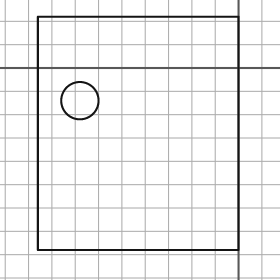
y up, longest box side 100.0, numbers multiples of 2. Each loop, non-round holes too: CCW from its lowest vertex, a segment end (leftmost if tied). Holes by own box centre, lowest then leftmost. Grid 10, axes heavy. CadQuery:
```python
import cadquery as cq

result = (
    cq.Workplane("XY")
    .moveTo(-86.0, -78.0)
    .lineTo(0.0, -78.0)
    .lineTo(0.0, 22.0)
    .lineTo(-86.0, 22.0)
    .close()
    .moveTo(-68.0, -14.0)
    .circle(8.0)
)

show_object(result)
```